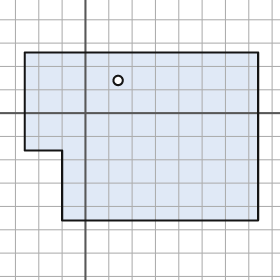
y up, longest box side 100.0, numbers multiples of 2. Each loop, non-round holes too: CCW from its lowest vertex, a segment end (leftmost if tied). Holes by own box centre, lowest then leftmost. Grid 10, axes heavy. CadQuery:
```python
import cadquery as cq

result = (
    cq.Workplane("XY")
    .moveTo(-10.0, -46.0)
    .lineTo(74.0, -46.0)
    .lineTo(74.0, 26.0)
    .lineTo(-26.0, 26.0)
    .lineTo(-26.0, -16.0)
    .lineTo(-10.0, -16.0)
    .close()
    .moveTo(14.0, 14.0)
    .circle(2.0)
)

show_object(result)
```